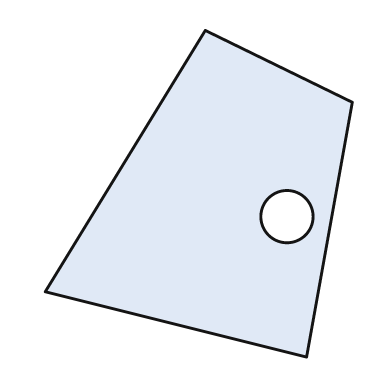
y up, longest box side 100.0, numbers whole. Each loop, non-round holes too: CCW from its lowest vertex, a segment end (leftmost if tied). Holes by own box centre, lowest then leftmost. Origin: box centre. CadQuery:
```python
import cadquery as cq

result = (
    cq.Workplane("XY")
    .moveTo(33.0, -50.0)
    .lineTo(47.0, 28.0)
    .lineTo(2.0, 50.0)
    .lineTo(-47.0, -30.0)
    .close()
    .moveTo(27.0, -7.0)
    .circle(8.0)
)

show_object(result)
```